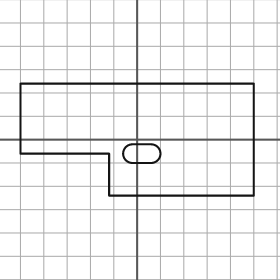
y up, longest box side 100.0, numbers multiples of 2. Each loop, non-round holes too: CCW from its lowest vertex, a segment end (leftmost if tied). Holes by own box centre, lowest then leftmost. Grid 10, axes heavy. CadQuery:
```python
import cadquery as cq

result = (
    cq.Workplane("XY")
    .moveTo(-12.0, -24.0)
    .lineTo(50.0, -24.0)
    .lineTo(50.0, 24.0)
    .lineTo(-50.0, 24.0)
    .lineTo(-50.0, -6.0)
    .lineTo(-12.0, -6.0)
    .close()
    .moveTo(-2.0, -10.0)
    .lineTo(6.0, -10.0)
    .threePointArc((10.0, -6.0), (6.0, -2.0))
    .lineTo(-2.0, -2.0)
    .threePointArc((-6.0, -6.0), (-2.0, -10.0))
    .close()
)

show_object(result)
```